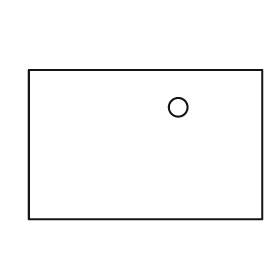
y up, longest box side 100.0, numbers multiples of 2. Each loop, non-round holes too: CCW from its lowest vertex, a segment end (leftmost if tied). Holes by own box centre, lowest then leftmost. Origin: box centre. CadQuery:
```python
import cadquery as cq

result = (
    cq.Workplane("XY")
    .moveTo(-50.0, -32.0)
    .lineTo(50.0, -32.0)
    .lineTo(50.0, 32.0)
    .lineTo(-50.0, 32.0)
    .close()
    .moveTo(14.0, 16.0)
    .circle(4.0)
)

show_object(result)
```